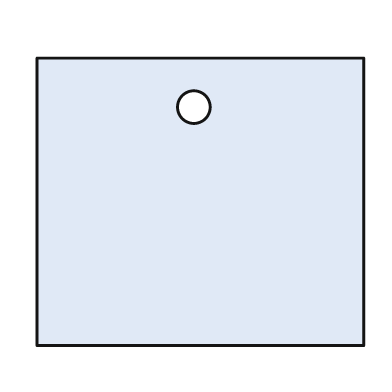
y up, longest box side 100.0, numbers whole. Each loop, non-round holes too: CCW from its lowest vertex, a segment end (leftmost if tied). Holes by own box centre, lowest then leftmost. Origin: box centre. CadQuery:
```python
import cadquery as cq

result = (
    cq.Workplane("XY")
    .moveTo(-50.0, -44.0)
    .lineTo(50.0, -44.0)
    .lineTo(50.0, 44.0)
    .lineTo(-50.0, 44.0)
    .close()
    .moveTo(-2.0, 29.0)
    .circle(5.0)
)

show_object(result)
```